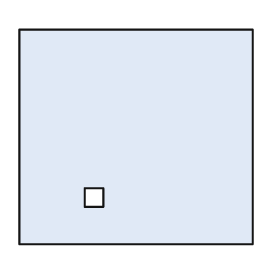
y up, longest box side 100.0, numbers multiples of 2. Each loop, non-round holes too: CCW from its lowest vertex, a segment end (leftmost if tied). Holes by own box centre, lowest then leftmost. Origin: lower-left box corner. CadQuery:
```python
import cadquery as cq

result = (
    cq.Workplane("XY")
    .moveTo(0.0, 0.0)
    .lineTo(100.0, 0.0)
    .lineTo(100.0, 92.0)
    .lineTo(0.0, 92.0)
    .close()
    .moveTo(28.0, 16.0)
    .lineTo(36.0, 16.0)
    .lineTo(36.0, 24.0)
    .lineTo(28.0, 24.0)
    .close()
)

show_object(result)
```